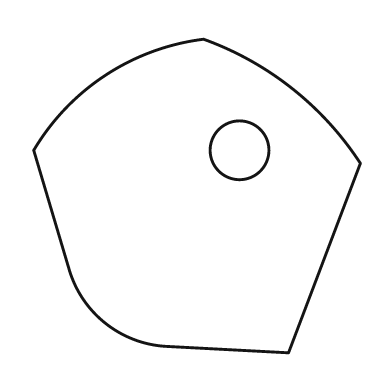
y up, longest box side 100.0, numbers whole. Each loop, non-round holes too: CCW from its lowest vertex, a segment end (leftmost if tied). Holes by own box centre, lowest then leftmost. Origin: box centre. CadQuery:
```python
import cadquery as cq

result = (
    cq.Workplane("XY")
    .moveTo(28.0, -48.0)
    .lineTo(50.0, 10.0)
    .threePointArc((29.0, 33.0), (2.0, 48.0))
    .threePointArc((-28.0, 37.0), (-50.0, 14.0))
    .lineTo(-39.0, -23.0)
    .threePointArc((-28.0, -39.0), (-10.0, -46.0))
    .close()
    .moveTo(13.0, 14.0)
    .circle(9.0)
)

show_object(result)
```